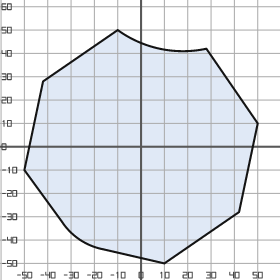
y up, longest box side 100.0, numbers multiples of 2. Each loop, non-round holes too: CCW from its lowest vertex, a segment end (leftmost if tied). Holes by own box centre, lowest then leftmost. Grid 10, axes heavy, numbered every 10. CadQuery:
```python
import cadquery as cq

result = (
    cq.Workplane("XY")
    .moveTo(10.0, -50.0)
    .lineTo(42.0, -28.0)
    .lineTo(50.0, 10.0)
    .lineTo(28.0, 42.0)
    .threePointArc((8.0, 42.0), (-10.0, 50.0))
    .lineTo(-42.0, 28.0)
    .lineTo(-50.0, -10.0)
    .lineTo(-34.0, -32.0)
    .threePointArc((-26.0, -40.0), (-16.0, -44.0))
    .close()
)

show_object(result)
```